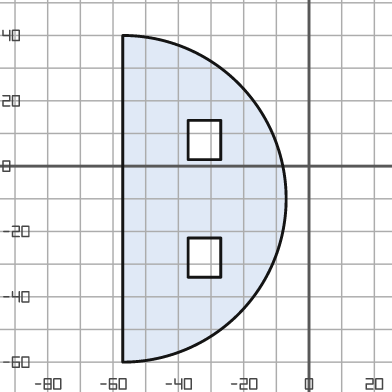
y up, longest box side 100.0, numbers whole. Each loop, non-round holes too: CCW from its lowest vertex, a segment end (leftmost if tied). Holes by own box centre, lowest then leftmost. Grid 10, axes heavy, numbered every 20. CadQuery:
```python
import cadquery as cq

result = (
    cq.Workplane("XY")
    .moveTo(-57.0, -60.0)
    .threePointArc((-7.0, -10.0), (-57.0, 40.0))
    .close()
    .moveTo(-37.0, -34.0)
    .lineTo(-27.0, -34.0)
    .lineTo(-27.0, -22.0)
    .lineTo(-37.0, -22.0)
    .close()
    .moveTo(-37.0, 2.0)
    .lineTo(-27.0, 2.0)
    .lineTo(-27.0, 14.0)
    .lineTo(-37.0, 14.0)
    .close()
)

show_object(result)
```